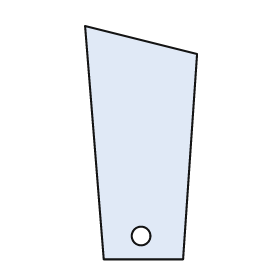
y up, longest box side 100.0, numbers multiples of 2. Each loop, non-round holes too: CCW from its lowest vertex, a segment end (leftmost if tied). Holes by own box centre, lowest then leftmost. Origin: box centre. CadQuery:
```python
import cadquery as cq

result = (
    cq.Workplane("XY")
    .moveTo(-16.0, -50.0)
    .lineTo(18.0, -50.0)
    .lineTo(24.0, 38.0)
    .lineTo(-24.0, 50.0)
    .close()
    .moveTo(0.0, -40.0)
    .circle(4.0)
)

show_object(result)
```